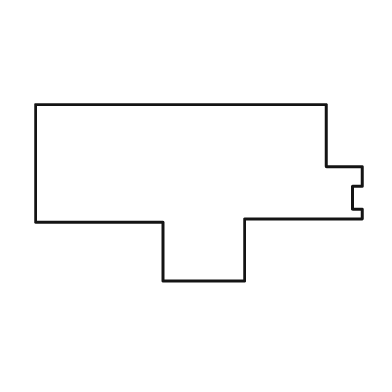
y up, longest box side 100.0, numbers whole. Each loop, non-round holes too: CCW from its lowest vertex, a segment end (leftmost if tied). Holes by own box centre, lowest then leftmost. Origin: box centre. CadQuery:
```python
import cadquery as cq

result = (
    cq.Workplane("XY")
    .moveTo(-11.0, -27.0)
    .lineTo(14.0, -27.0)
    .lineTo(14.0, -8.0)
    .lineTo(50.0, -8.0)
    .lineTo(50.0, -5.0)
    .lineTo(47.0, -5.0)
    .lineTo(47.0, 2.0)
    .lineTo(50.0, 2.0)
    .lineTo(50.0, 8.0)
    .lineTo(39.0, 8.0)
    .lineTo(39.0, 27.0)
    .lineTo(-50.0, 27.0)
    .lineTo(-50.0, -9.0)
    .lineTo(-11.0, -9.0)
    .close()
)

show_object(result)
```